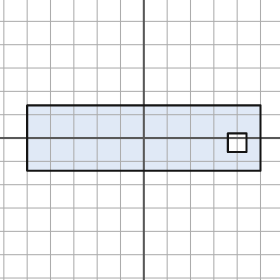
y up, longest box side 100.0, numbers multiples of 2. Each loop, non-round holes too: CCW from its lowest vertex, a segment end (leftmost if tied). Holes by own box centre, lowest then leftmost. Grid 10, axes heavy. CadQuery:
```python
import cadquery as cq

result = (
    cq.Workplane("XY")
    .moveTo(-50.0, -14.0)
    .lineTo(50.0, -14.0)
    .lineTo(50.0, 14.0)
    .lineTo(-50.0, 14.0)
    .close()
    .moveTo(36.0, -6.0)
    .lineTo(44.0, -6.0)
    .lineTo(44.0, 2.0)
    .lineTo(36.0, 2.0)
    .close()
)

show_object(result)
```